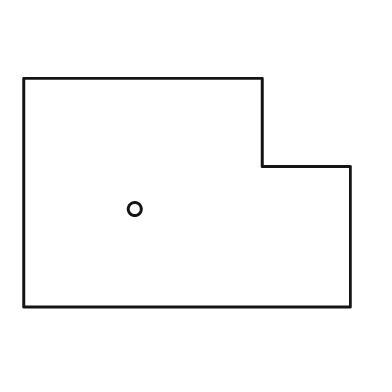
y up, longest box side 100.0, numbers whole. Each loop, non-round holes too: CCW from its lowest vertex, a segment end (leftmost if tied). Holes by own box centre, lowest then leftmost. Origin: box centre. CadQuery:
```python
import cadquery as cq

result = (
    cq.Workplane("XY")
    .moveTo(-50.0, -35.0)
    .lineTo(50.0, -35.0)
    .lineTo(50.0, 8.0)
    .lineTo(23.0, 8.0)
    .lineTo(23.0, 35.0)
    .lineTo(-50.0, 35.0)
    .close()
    .moveTo(-16.0, -5.0)
    .circle(2.0)
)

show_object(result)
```